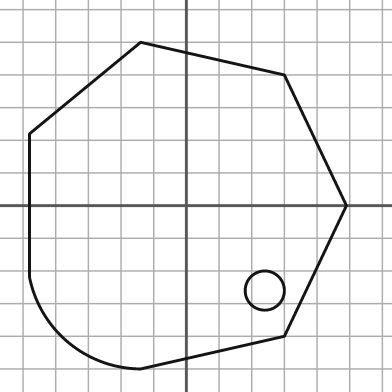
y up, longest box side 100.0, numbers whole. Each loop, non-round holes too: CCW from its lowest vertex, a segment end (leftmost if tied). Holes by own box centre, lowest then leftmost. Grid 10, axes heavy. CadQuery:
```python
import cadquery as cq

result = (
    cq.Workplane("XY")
    .moveTo(-14.0, -50.0)
    .lineTo(30.0, -40.0)
    .lineTo(49.0, 0.0)
    .lineTo(30.0, 40.0)
    .lineTo(-14.0, 50.0)
    .lineTo(-48.0, 22.0)
    .lineTo(-48.0, -22.0)
    .threePointArc((-36.0, -42.0), (-14.0, -50.0))
    .close()
    .moveTo(24.0, -26.0)
    .circle(6.0)
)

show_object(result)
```